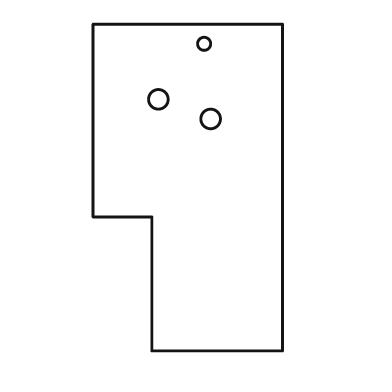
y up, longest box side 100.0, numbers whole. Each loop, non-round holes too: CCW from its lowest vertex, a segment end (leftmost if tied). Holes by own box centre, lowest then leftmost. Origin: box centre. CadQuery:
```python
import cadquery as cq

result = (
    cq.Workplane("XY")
    .moveTo(-11.0, -50.0)
    .lineTo(29.0, -50.0)
    .lineTo(29.0, 50.0)
    .lineTo(-29.0, 50.0)
    .lineTo(-29.0, -9.0)
    .lineTo(-11.0, -9.0)
    .close()
    .moveTo(7.0, 21.0)
    .circle(3.0)
    .moveTo(-9.0, 27.0)
    .circle(3.0)
    .moveTo(5.0, 44.0)
    .circle(2.0)
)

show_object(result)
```